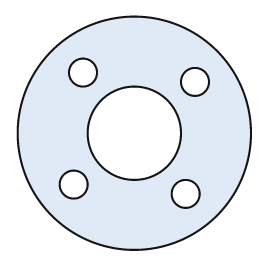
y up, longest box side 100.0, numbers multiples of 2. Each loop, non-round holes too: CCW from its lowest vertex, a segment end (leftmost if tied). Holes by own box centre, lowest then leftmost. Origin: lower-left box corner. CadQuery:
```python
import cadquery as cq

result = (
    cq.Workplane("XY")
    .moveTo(50.0, 50.0)
    .circle(50.0)
    .moveTo(72.0, 24.0)
    .circle(6.0)
    .moveTo(24.0, 28.0)
    .circle(6.0)
    .moveTo(50.0, 50.0)
    .circle(20.0)
    .moveTo(76.0, 72.0)
    .circle(6.0)
    .moveTo(28.0, 76.0)
    .circle(6.0)
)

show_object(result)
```